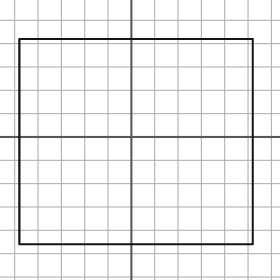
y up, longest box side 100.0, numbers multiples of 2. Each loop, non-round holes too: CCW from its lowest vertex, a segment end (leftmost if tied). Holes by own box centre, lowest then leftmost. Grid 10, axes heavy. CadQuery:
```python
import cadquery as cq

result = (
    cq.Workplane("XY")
    .moveTo(-48.0, -46.0)
    .lineTo(52.0, -46.0)
    .lineTo(52.0, 42.0)
    .lineTo(-48.0, 42.0)
    .close()
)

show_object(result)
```